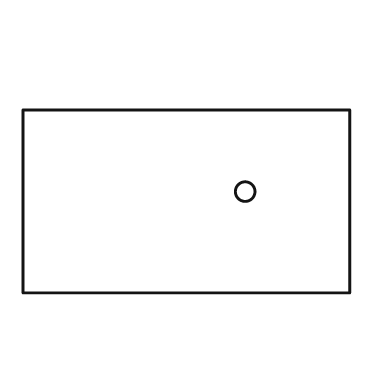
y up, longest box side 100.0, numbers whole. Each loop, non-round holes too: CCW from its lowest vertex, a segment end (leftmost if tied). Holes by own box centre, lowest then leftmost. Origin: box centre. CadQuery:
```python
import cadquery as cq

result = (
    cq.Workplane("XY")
    .moveTo(-50.0, -28.0)
    .lineTo(50.0, -28.0)
    .lineTo(50.0, 28.0)
    .lineTo(-50.0, 28.0)
    .close()
    .moveTo(18.0, 3.0)
    .circle(3.0)
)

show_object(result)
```